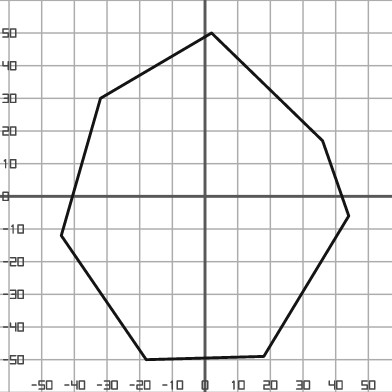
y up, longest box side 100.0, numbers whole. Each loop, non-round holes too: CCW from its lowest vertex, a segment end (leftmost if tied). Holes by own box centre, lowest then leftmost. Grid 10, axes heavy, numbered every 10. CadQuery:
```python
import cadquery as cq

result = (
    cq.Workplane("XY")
    .moveTo(-18.0, -50.0)
    .lineTo(18.0, -49.0)
    .lineTo(44.0, -6.0)
    .lineTo(36.0, 17.0)
    .lineTo(2.0, 50.0)
    .lineTo(-32.0, 30.0)
    .lineTo(-44.0, -12.0)
    .close()
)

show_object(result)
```